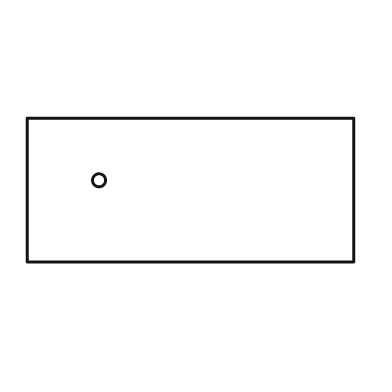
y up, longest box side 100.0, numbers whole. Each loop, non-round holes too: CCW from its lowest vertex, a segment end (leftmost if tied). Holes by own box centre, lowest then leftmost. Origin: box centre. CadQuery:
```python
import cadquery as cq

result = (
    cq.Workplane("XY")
    .moveTo(-50.0, -22.0)
    .lineTo(50.0, -22.0)
    .lineTo(50.0, 22.0)
    .lineTo(-50.0, 22.0)
    .close()
    .moveTo(-28.0, 3.0)
    .circle(2.0)
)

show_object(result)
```